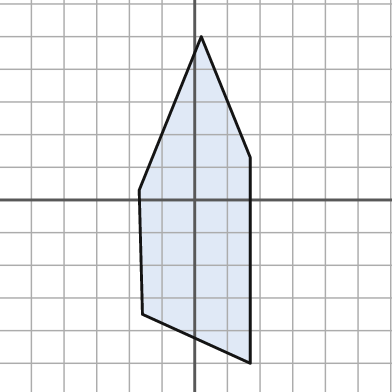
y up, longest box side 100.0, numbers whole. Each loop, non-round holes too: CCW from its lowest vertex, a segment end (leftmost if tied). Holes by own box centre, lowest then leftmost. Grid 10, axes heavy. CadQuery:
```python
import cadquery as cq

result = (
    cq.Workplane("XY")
    .moveTo(17.0, -50.0)
    .lineTo(17.0, 13.0)
    .lineTo(2.0, 50.0)
    .lineTo(-17.0, 3.0)
    .lineTo(-16.0, -35.0)
    .close()
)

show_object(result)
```